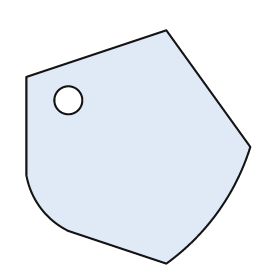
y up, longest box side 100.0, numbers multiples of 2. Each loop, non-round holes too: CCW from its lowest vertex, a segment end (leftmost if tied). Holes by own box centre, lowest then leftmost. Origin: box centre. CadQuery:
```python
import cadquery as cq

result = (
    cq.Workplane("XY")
    .moveTo(12.0, -50.0)
    .threePointArc((34.0, -28.0), (48.0, 0.0))
    .lineTo(12.0, 50.0)
    .lineTo(-48.0, 30.0)
    .lineTo(-48.0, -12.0)
    .threePointArc((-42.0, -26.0), (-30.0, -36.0))
    .close()
    .moveTo(-30.0, 20.0)
    .circle(6.0)
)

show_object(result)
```